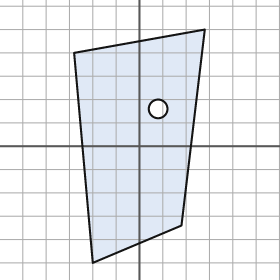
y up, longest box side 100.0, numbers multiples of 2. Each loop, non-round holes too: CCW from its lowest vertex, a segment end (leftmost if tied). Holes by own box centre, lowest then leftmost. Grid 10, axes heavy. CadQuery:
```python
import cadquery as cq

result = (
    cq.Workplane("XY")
    .moveTo(-20.0, -50.0)
    .lineTo(18.0, -34.0)
    .lineTo(28.0, 50.0)
    .lineTo(-28.0, 40.0)
    .close()
    .moveTo(8.0, 16.0)
    .circle(4.0)
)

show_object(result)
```